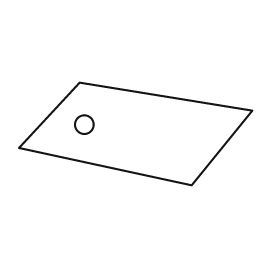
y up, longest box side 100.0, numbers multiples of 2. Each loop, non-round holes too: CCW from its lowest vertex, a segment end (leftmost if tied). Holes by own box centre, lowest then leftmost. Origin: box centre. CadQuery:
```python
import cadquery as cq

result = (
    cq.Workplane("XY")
    .moveTo(24.0, -22.0)
    .lineTo(50.0, 10.0)
    .lineTo(-24.0, 22.0)
    .lineTo(-50.0, -6.0)
    .close()
    .moveTo(-22.0, 4.0)
    .circle(4.0)
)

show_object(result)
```